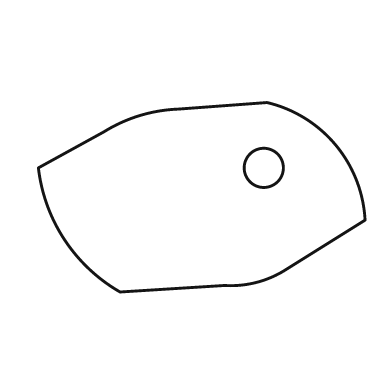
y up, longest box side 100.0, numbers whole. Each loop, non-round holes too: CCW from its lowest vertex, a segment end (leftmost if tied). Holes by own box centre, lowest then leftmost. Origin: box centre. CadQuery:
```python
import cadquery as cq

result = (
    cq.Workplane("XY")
    .moveTo(-25.0, -29.0)
    .lineTo(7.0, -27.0)
    .threePointArc((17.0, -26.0), (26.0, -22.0))
    .lineTo(50.0, -7.0)
    .threePointArc((41.0, 16.0), (20.0, 29.0))
    .lineTo(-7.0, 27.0)
    .threePointArc((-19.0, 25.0), (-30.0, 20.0))
    .lineTo(-50.0, 9.0)
    .threePointArc((-42.0, -13.0), (-25.0, -29.0))
    .close()
    .moveTo(19.0, 9.0)
    .circle(6.0)
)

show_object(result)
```